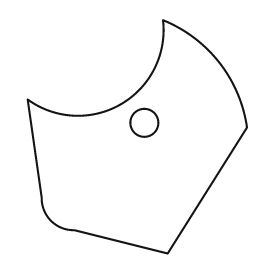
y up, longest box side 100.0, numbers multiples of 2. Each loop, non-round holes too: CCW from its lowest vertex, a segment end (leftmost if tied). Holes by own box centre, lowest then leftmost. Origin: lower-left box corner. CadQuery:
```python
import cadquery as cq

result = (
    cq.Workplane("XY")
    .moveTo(60.0, 0.0)
    .lineTo(94.0, 54.0)
    .threePointArc((82.0, 82.0), (58.0, 100.0))
    .threePointArc((40.0, 64.0), (0.0, 66.0))
    .lineTo(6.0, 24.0)
    .threePointArc((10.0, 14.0), (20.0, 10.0))
    .close()
    .moveTo(50.0, 56.0)
    .circle(6.0)
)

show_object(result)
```